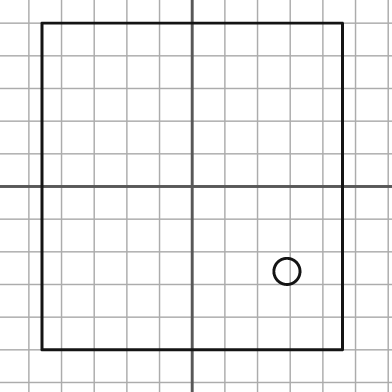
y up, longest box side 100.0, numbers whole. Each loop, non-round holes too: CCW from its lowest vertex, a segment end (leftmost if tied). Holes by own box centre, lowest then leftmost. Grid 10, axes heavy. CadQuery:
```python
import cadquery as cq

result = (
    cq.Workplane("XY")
    .moveTo(-46.0, -50.0)
    .lineTo(46.0, -50.0)
    .lineTo(46.0, 50.0)
    .lineTo(-46.0, 50.0)
    .close()
    .moveTo(29.0, -26.0)
    .circle(4.0)
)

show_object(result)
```